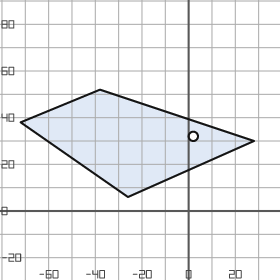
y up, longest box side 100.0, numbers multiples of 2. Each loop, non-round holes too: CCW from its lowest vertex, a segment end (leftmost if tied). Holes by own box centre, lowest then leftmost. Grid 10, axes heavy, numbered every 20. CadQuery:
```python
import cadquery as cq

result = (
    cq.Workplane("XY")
    .moveTo(-26.0, 6.0)
    .lineTo(28.0, 30.0)
    .lineTo(-38.0, 52.0)
    .lineTo(-72.0, 38.0)
    .close()
    .moveTo(2.0, 32.0)
    .circle(2.0)
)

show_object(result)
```